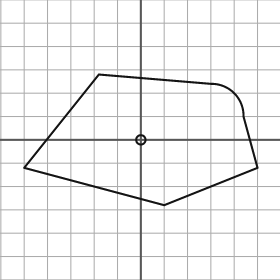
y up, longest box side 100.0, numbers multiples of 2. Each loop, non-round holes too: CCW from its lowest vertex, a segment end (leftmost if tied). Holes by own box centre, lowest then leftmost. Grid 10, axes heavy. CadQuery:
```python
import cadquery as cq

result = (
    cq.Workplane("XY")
    .moveTo(10.0, -28.0)
    .lineTo(50.0, -12.0)
    .lineTo(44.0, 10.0)
    .threePointArc((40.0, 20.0), (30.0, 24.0))
    .lineTo(-18.0, 28.0)
    .lineTo(-50.0, -12.0)
    .close()
    .moveTo(0.0, 0.0)
    .circle(2.0)
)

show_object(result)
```